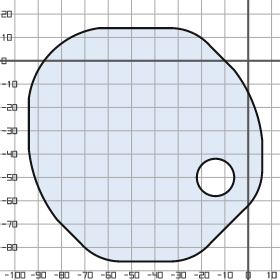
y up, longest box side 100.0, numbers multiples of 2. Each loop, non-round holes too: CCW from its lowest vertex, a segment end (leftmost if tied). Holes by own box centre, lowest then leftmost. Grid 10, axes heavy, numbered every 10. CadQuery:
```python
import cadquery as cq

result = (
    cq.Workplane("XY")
    .moveTo(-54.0, -86.0)
    .lineTo(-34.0, -86.0)
    .threePointArc((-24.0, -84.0), (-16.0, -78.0))
    .lineTo(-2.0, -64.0)
    .threePointArc((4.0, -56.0), (6.0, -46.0))
    .lineTo(6.0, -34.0)
    .threePointArc((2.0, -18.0), (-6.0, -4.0))
    .lineTo(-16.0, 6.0)
    .threePointArc((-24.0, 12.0), (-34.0, 14.0))
    .lineTo(-64.0, 14.0)
    .threePointArc((-84.0, 4.0), (-94.0, -16.0))
    .lineTo(-94.0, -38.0)
    .threePointArc((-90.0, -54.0), (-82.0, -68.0))
    .lineTo(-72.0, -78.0)
    .threePointArc((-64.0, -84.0), (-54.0, -86.0))
    .close()
    .moveTo(-14.0, -50.0)
    .circle(8.0)
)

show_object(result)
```